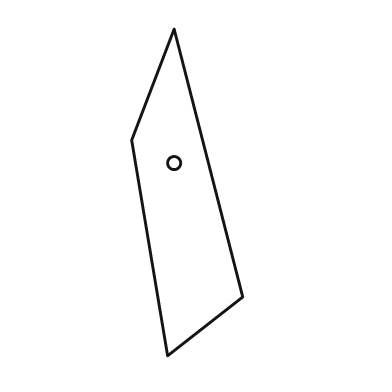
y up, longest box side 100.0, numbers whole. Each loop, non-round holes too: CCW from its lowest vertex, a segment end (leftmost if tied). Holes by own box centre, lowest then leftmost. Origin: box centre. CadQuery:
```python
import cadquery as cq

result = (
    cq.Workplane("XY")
    .moveTo(-6.0, -50.0)
    .lineTo(17.0, -32.0)
    .lineTo(-4.0, 50.0)
    .lineTo(-17.0, 16.0)
    .close()
    .moveTo(-4.0, 9.0)
    .circle(2.0)
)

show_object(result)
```